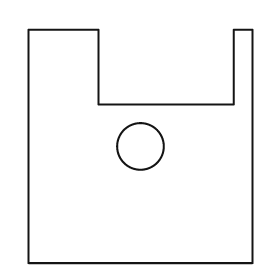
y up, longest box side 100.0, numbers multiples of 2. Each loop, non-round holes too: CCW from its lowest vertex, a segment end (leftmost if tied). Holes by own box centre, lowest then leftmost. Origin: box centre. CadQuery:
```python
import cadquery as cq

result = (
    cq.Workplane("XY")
    .moveTo(-48.0, -50.0)
    .lineTo(48.0, -50.0)
    .lineTo(48.0, 50.0)
    .lineTo(40.0, 50.0)
    .lineTo(40.0, 18.0)
    .lineTo(-18.0, 18.0)
    .lineTo(-18.0, 50.0)
    .lineTo(-48.0, 50.0)
    .close()
    .moveTo(0.0, 0.0)
    .circle(10.0)
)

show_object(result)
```